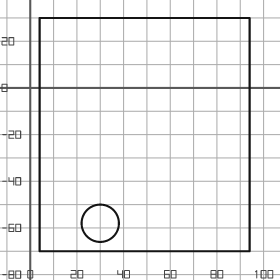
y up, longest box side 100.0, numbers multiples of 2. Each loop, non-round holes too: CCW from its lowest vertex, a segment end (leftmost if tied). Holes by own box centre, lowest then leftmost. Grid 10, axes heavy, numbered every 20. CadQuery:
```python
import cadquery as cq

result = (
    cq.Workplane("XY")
    .moveTo(4.0, -70.0)
    .lineTo(94.0, -70.0)
    .lineTo(94.0, 30.0)
    .lineTo(4.0, 30.0)
    .close()
    .moveTo(30.0, -58.0)
    .circle(8.0)
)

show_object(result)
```